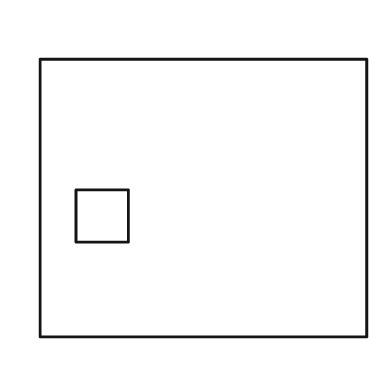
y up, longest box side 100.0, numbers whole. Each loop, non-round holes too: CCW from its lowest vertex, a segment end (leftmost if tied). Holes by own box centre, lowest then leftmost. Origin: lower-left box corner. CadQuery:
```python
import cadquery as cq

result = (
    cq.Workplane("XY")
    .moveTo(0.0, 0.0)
    .lineTo(100.0, 0.0)
    .lineTo(100.0, 85.0)
    .lineTo(0.0, 85.0)
    .close()
    .moveTo(11.0, 29.0)
    .lineTo(27.0, 29.0)
    .lineTo(27.0, 45.0)
    .lineTo(11.0, 45.0)
    .close()
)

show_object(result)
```